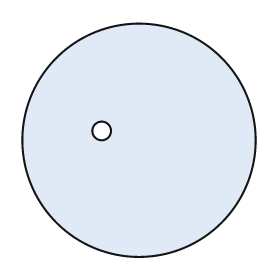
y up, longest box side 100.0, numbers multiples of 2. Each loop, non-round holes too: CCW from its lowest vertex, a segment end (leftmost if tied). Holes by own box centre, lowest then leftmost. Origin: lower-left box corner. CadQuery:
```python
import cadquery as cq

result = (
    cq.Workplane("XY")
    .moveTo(50.0, 50.0)
    .circle(50.0)
    .moveTo(34.0, 54.0)
    .circle(4.0)
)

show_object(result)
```